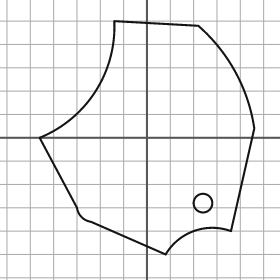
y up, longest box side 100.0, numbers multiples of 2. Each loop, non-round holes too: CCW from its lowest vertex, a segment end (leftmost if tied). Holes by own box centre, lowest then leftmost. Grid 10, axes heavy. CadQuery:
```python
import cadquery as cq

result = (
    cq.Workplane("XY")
    .moveTo(8.0, -50.0)
    .threePointArc((20.0, -40.0), (36.0, -40.0))
    .lineTo(46.0, 4.0)
    .threePointArc((38.0, 28.0), (22.0, 48.0))
    .lineTo(-14.0, 50.0)
    .threePointArc((-22.0, 20.0), (-46.0, 0.0))
    .lineTo(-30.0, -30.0)
    .threePointArc((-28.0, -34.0), (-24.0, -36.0))
    .close()
    .moveTo(24.0, -28.0)
    .circle(4.0)
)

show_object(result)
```